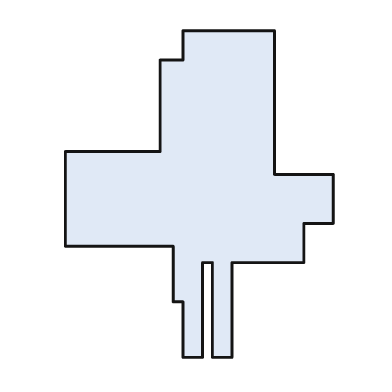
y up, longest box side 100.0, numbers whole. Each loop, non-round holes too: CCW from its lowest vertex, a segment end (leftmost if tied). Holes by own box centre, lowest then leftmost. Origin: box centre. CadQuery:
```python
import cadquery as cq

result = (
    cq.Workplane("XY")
    .moveTo(-5.0, -50.0)
    .lineTo(1.0, -50.0)
    .lineTo(1.0, -21.0)
    .lineTo(4.0, -21.0)
    .lineTo(4.0, -50.0)
    .lineTo(10.0, -50.0)
    .lineTo(10.0, -21.0)
    .lineTo(32.0, -21.0)
    .lineTo(32.0, -9.0)
    .lineTo(41.0, -9.0)
    .lineTo(41.0, 6.0)
    .lineTo(23.0, 6.0)
    .lineTo(23.0, 50.0)
    .lineTo(-5.0, 50.0)
    .lineTo(-5.0, 41.0)
    .lineTo(-12.0, 41.0)
    .lineTo(-12.0, 13.0)
    .lineTo(-41.0, 13.0)
    .lineTo(-41.0, -16.0)
    .lineTo(-8.0, -16.0)
    .lineTo(-8.0, -33.0)
    .lineTo(-5.0, -33.0)
    .close()
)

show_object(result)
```